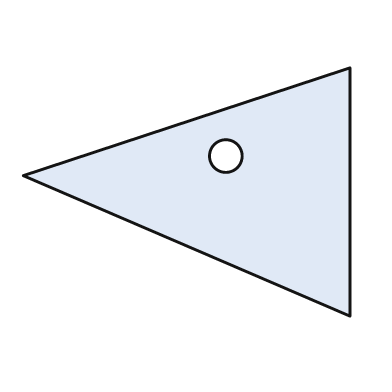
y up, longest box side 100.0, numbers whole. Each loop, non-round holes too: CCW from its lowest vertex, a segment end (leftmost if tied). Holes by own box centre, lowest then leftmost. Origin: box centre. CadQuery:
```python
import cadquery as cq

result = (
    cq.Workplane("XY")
    .moveTo(50.0, -38.0)
    .lineTo(50.0, 38.0)
    .lineTo(-50.0, 5.0)
    .close()
    .moveTo(12.0, 11.0)
    .circle(5.0)
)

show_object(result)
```